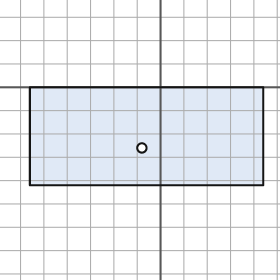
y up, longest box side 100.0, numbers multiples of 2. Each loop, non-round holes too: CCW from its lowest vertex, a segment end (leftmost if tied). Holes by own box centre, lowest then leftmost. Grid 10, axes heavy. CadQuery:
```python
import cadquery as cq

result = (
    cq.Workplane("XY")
    .moveTo(-56.0, -42.0)
    .lineTo(44.0, -42.0)
    .lineTo(44.0, 0.0)
    .lineTo(-56.0, 0.0)
    .close()
    .moveTo(-8.0, -26.0)
    .circle(2.0)
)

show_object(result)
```